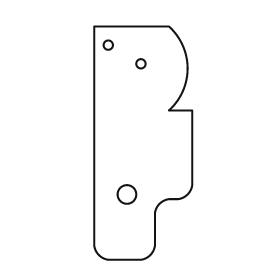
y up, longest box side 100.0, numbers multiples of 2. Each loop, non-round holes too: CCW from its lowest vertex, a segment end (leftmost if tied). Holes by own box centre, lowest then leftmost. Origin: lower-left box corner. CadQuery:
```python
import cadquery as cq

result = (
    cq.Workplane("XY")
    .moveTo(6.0, 0.0)
    .lineTo(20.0, 0.0)
    .threePointArc((24.0, 2.0), (26.0, 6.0))
    .lineTo(26.0, 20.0)
    .threePointArc((28.0, 24.0), (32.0, 26.0))
    .lineTo(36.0, 26.0)
    .threePointArc((40.0, 28.0), (42.0, 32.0))
    .lineTo(42.0, 64.0)
    .lineTo(32.0, 64.0)
    .threePointArc((40.0, 82.0), (32.0, 100.0))
    .lineTo(0.0, 100.0)
    .lineTo(0.0, 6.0)
    .threePointArc((2.0, 2.0), (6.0, 0.0))
    .close()
    .moveTo(14.0, 28.0)
    .circle(4.0)
    .moveTo(20.0, 84.0)
    .circle(2.0)
    .moveTo(6.0, 92.0)
    .circle(2.0)
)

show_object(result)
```